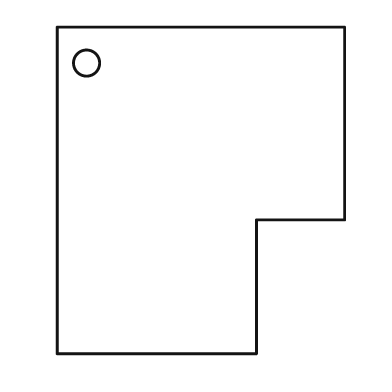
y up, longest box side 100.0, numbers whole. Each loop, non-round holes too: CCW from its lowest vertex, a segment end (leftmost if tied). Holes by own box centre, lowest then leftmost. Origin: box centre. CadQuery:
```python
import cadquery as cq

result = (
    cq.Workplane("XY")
    .moveTo(-44.0, -50.0)
    .lineTo(17.0, -50.0)
    .lineTo(17.0, -9.0)
    .lineTo(44.0, -9.0)
    .lineTo(44.0, 50.0)
    .lineTo(-44.0, 50.0)
    .close()
    .moveTo(-35.0, 39.0)
    .circle(4.0)
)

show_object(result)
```